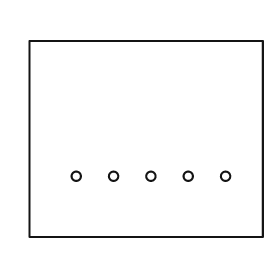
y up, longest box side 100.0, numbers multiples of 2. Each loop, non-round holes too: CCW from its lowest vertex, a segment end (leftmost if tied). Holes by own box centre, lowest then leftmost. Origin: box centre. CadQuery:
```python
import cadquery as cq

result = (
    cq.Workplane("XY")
    .moveTo(-50.0, -42.0)
    .lineTo(50.0, -42.0)
    .lineTo(50.0, 42.0)
    .lineTo(-50.0, 42.0)
    .close()
    .moveTo(-30.0, -16.0)
    .circle(2.0)
    .moveTo(-14.0, -16.0)
    .circle(2.0)
    .moveTo(2.0, -16.0)
    .circle(2.0)
    .moveTo(18.0, -16.0)
    .circle(2.0)
    .moveTo(34.0, -16.0)
    .circle(2.0)
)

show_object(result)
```